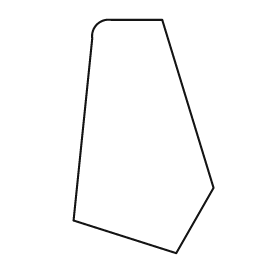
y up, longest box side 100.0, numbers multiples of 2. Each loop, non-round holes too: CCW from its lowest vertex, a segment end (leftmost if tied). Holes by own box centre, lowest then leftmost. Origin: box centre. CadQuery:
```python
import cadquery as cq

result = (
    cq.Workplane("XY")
    .moveTo(14.0, -50.0)
    .lineTo(30.0, -22.0)
    .lineTo(8.0, 50.0)
    .lineTo(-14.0, 50.0)
    .threePointArc((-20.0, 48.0), (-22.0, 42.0))
    .lineTo(-30.0, -36.0)
    .close()
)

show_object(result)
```